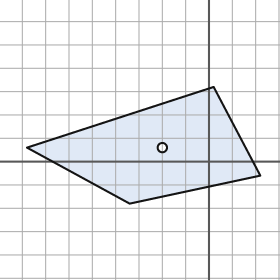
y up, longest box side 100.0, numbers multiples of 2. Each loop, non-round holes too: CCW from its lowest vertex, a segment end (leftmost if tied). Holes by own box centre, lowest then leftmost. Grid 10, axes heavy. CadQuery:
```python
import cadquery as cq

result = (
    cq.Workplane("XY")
    .moveTo(-34.0, -18.0)
    .lineTo(22.0, -6.0)
    .lineTo(2.0, 32.0)
    .lineTo(-78.0, 6.0)
    .close()
    .moveTo(-20.0, 6.0)
    .circle(2.0)
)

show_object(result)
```